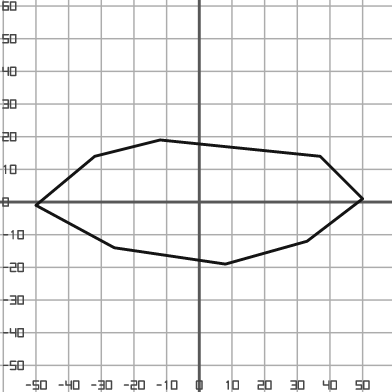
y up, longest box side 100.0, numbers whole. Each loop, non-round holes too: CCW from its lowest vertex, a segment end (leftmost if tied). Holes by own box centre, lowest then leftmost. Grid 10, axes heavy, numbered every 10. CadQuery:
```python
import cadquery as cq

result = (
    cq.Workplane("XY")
    .moveTo(8.0, -19.0)
    .lineTo(33.0, -12.0)
    .lineTo(50.0, 1.0)
    .lineTo(37.0, 14.0)
    .lineTo(-12.0, 19.0)
    .lineTo(-32.0, 14.0)
    .lineTo(-50.0, -1.0)
    .lineTo(-26.0, -14.0)
    .close()
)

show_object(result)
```